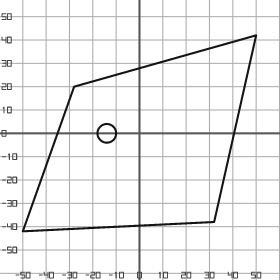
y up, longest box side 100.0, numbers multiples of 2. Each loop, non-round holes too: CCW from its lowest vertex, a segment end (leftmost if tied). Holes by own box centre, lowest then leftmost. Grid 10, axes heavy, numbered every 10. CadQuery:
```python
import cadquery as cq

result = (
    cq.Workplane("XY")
    .moveTo(-50.0, -42.0)
    .lineTo(32.0, -38.0)
    .lineTo(50.0, 42.0)
    .lineTo(-28.0, 20.0)
    .close()
    .moveTo(-14.0, 0.0)
    .circle(4.0)
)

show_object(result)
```